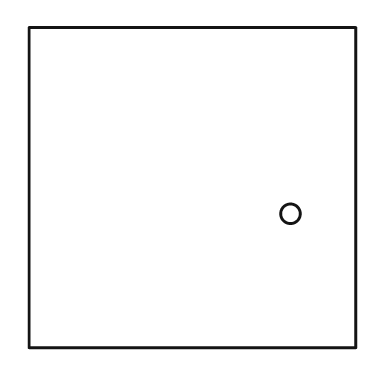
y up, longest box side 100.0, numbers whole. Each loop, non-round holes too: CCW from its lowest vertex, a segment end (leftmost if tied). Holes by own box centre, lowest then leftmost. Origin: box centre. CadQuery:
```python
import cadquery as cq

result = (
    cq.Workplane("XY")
    .moveTo(-50.0, -49.0)
    .lineTo(50.0, -49.0)
    .lineTo(50.0, 49.0)
    .lineTo(-50.0, 49.0)
    .close()
    .moveTo(30.0, -8.0)
    .circle(3.0)
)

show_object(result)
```